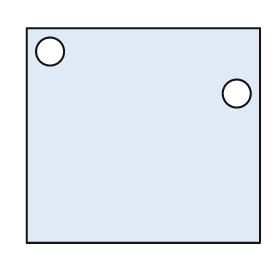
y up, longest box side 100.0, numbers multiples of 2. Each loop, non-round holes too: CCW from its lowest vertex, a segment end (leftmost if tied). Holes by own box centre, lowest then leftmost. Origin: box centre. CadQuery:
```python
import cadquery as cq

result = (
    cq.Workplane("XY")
    .moveTo(-50.0, -46.0)
    .lineTo(50.0, -46.0)
    .lineTo(50.0, 46.0)
    .lineTo(-50.0, 46.0)
    .close()
    .moveTo(40.0, 18.0)
    .circle(6.0)
    .moveTo(-40.0, 36.0)
    .circle(6.0)
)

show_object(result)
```